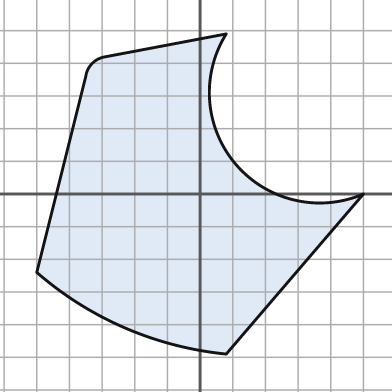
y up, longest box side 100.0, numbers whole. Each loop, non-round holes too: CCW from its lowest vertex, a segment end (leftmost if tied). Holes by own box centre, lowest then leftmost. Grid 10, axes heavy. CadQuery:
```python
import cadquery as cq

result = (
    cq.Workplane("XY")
    .moveTo(8.0, -49.0)
    .lineTo(50.0, 0.0)
    .threePointArc((11.0, 9.0), (8.0, 49.0))
    .lineTo(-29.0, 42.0)
    .threePointArc((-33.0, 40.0), (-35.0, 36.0))
    .lineTo(-50.0, -24.0)
    .threePointArc((-23.0, -41.0), (8.0, -49.0))
    .close()
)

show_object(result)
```